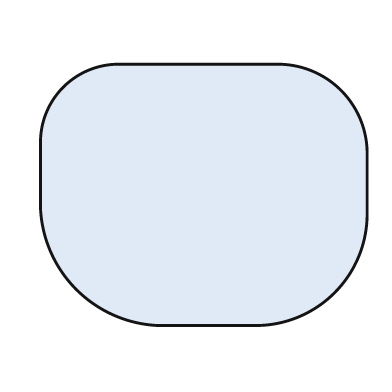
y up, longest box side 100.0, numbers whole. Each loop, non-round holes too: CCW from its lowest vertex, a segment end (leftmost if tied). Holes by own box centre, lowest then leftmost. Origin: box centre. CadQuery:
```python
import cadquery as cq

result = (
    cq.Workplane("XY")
    .moveTo(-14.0, -40.0)
    .lineTo(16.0, -40.0)
    .threePointArc((40.0, -30.0), (50.0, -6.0))
    .lineTo(50.0, 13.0)
    .threePointArc((42.0, 32.0), (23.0, 40.0))
    .lineTo(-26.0, 40.0)
    .threePointArc((-43.0, 33.0), (-50.0, 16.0))
    .lineTo(-50.0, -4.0)
    .threePointArc((-39.0, -29.0), (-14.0, -40.0))
    .close()
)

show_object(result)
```